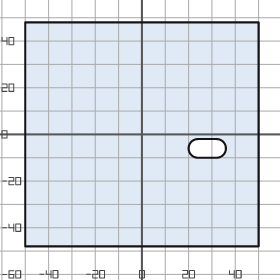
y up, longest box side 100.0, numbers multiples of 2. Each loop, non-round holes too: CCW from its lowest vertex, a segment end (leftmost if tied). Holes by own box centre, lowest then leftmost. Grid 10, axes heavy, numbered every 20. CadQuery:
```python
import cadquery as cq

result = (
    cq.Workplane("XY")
    .moveTo(-50.0, -48.0)
    .lineTo(50.0, -48.0)
    .lineTo(50.0, 48.0)
    .lineTo(-50.0, 48.0)
    .close()
    .moveTo(24.0, -10.0)
    .lineTo(32.0, -10.0)
    .threePointArc((36.0, -6.0), (32.0, -2.0))
    .lineTo(24.0, -2.0)
    .threePointArc((20.0, -6.0), (24.0, -10.0))
    .close()
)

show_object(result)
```